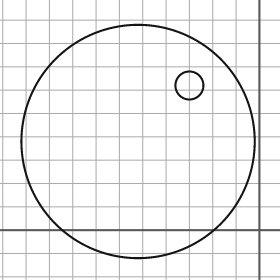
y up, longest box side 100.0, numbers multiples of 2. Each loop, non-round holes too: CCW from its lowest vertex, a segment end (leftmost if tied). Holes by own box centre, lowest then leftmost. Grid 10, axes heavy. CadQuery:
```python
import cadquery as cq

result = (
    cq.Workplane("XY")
    .moveTo(-52.0, 38.0)
    .circle(50.0)
    .moveTo(-30.0, 62.0)
    .circle(6.0)
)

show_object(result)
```